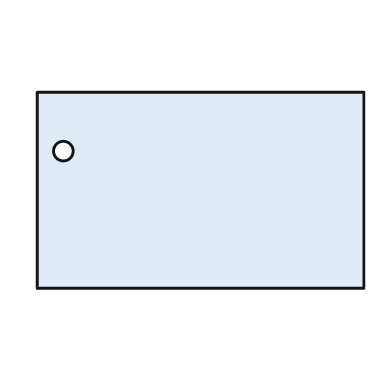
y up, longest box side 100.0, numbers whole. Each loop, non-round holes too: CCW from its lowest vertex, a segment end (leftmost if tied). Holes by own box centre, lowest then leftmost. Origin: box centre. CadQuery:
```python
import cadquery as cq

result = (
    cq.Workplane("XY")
    .moveTo(-50.0, -30.0)
    .lineTo(50.0, -30.0)
    .lineTo(50.0, 30.0)
    .lineTo(-50.0, 30.0)
    .close()
    .moveTo(-42.0, 12.0)
    .circle(3.0)
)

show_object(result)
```